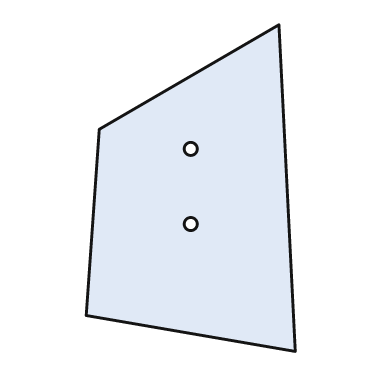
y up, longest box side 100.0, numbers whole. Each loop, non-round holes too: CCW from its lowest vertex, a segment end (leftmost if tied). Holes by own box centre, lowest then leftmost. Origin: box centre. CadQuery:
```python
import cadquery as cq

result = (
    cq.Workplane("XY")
    .moveTo(32.0, -50.0)
    .lineTo(27.0, 50.0)
    .lineTo(-28.0, 18.0)
    .lineTo(-32.0, -39.0)
    .close()
    .moveTo(0.0, -11.0)
    .circle(2.0)
    .moveTo(0.0, 12.0)
    .circle(2.0)
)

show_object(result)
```